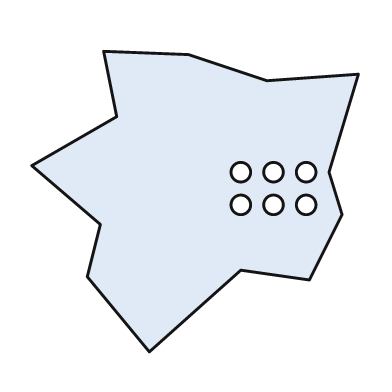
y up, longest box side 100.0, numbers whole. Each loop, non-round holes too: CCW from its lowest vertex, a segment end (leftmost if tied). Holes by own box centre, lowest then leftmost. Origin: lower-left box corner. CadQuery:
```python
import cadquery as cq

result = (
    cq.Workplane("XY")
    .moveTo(36.0, 0.0)
    .lineTo(64.0, 25.0)
    .lineTo(85.0, 22.0)
    .lineTo(95.0, 42.0)
    .lineTo(91.0, 55.0)
    .lineTo(100.0, 85.0)
    .lineTo(72.0, 83.0)
    .lineTo(48.0, 91.0)
    .lineTo(22.0, 92.0)
    .lineTo(26.0, 72.0)
    .lineTo(0.0, 57.0)
    .lineTo(21.0, 39.0)
    .lineTo(17.0, 23.0)
    .close()
    .moveTo(64.0, 45.0)
    .circle(3.0)
    .moveTo(74.0, 45.0)
    .circle(3.0)
    .moveTo(84.0, 45.0)
    .circle(3.0)
    .moveTo(64.0, 55.0)
    .circle(3.0)
    .moveTo(74.0, 55.0)
    .circle(3.0)
    .moveTo(84.0, 55.0)
    .circle(3.0)
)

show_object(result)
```